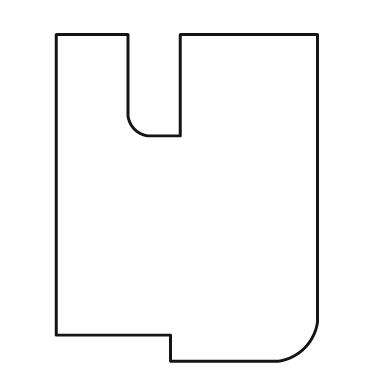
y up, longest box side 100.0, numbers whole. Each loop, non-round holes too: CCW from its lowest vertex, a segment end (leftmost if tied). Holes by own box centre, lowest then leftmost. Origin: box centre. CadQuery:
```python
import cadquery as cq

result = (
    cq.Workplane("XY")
    .moveTo(-5.0, -50.0)
    .lineTo(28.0, -50.0)
    .threePointArc((36.0, -46.0), (40.0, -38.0))
    .lineTo(40.0, 50.0)
    .lineTo(-2.0, 50.0)
    .lineTo(-2.0, 19.0)
    .lineTo(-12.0, 19.0)
    .threePointArc((-16.0, 21.0), (-18.0, 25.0))
    .lineTo(-18.0, 50.0)
    .lineTo(-40.0, 50.0)
    .lineTo(-40.0, -42.0)
    .lineTo(-5.0, -42.0)
    .close()
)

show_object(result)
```